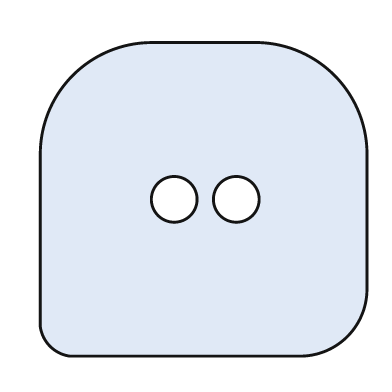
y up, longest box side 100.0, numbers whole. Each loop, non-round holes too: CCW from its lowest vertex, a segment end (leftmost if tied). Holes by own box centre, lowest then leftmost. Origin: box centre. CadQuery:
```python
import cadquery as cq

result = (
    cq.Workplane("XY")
    .moveTo(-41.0, -48.0)
    .lineTo(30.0, -48.0)
    .threePointArc((44.0, -42.0), (50.0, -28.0))
    .lineTo(50.0, 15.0)
    .threePointArc((40.0, 38.0), (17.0, 48.0))
    .lineTo(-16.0, 48.0)
    .threePointArc((-40.0, 38.0), (-50.0, 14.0))
    .lineTo(-50.0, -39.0)
    .threePointArc((-47.0, -45.0), (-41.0, -48.0))
    .close()
    .moveTo(-9.0, 0.0)
    .circle(7.0)
    .moveTo(10.0, 0.0)
    .circle(7.0)
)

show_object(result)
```